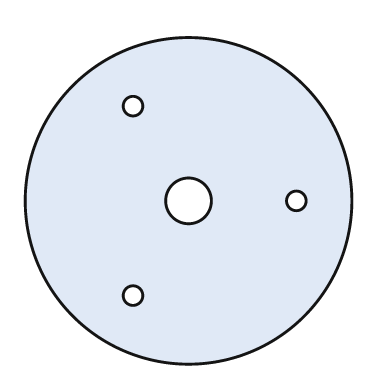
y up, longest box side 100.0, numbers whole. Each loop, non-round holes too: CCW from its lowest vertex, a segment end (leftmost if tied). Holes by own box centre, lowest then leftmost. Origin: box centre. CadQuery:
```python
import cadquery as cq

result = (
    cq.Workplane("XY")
    .moveTo(0.0, 0.0)
    .circle(50.0)
    .moveTo(-17.0, -29.0)
    .circle(3.0)
    .moveTo(0.0, 0.0)
    .circle(7.0)
    .moveTo(33.0, 0.0)
    .circle(3.0)
    .moveTo(-17.0, 29.0)
    .circle(3.0)
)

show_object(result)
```